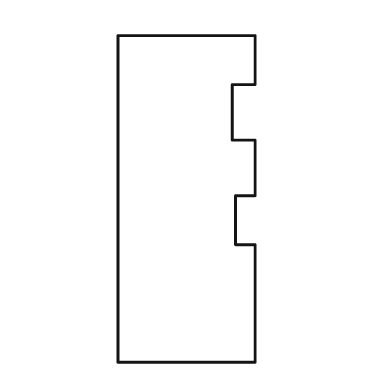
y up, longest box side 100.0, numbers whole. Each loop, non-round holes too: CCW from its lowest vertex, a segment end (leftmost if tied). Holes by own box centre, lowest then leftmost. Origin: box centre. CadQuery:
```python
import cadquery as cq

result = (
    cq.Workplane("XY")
    .moveTo(-21.0, -50.0)
    .lineTo(21.0, -50.0)
    .lineTo(21.0, -14.0)
    .lineTo(15.0, -14.0)
    .lineTo(15.0, 1.0)
    .lineTo(21.0, 1.0)
    .lineTo(21.0, 18.0)
    .lineTo(14.0, 18.0)
    .lineTo(14.0, 35.0)
    .lineTo(21.0, 35.0)
    .lineTo(21.0, 50.0)
    .lineTo(-21.0, 50.0)
    .close()
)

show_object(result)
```